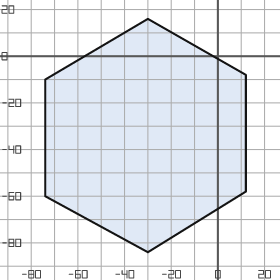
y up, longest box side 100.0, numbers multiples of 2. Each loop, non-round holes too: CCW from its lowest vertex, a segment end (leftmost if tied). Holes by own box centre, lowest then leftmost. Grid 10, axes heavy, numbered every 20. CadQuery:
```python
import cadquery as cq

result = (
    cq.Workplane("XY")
    .moveTo(-30.0, -84.0)
    .lineTo(12.0, -58.0)
    .lineTo(12.0, -8.0)
    .lineTo(-30.0, 16.0)
    .lineTo(-74.0, -10.0)
    .lineTo(-74.0, -60.0)
    .close()
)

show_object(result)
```